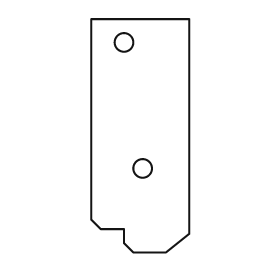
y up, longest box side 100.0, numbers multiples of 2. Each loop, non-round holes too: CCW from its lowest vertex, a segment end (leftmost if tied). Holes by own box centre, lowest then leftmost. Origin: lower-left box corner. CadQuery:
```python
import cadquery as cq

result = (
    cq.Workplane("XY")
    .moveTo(18.0, 0.0)
    .lineTo(32.0, 0.0)
    .lineTo(42.0, 8.0)
    .lineTo(42.0, 100.0)
    .lineTo(0.0, 100.0)
    .lineTo(0.0, 14.0)
    .lineTo(4.0, 10.0)
    .lineTo(14.0, 10.0)
    .lineTo(14.0, 4.0)
    .close()
    .moveTo(22.0, 36.0)
    .circle(4.0)
    .moveTo(14.0, 90.0)
    .circle(4.0)
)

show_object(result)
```